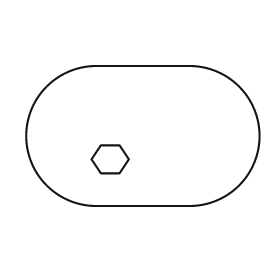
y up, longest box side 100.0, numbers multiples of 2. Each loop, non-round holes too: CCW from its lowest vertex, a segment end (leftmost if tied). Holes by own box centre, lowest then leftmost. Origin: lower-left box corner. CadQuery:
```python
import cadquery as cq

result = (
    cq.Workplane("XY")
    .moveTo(30.0, 0.0)
    .lineTo(70.0, 0.0)
    .threePointArc((100.0, 30.0), (70.0, 60.0))
    .lineTo(30.0, 60.0)
    .threePointArc((0.0, 30.0), (30.0, 0.0))
    .close()
    .moveTo(32.0, 14.0)
    .lineTo(40.0, 14.0)
    .lineTo(44.0, 20.0)
    .lineTo(40.0, 26.0)
    .lineTo(32.0, 26.0)
    .lineTo(28.0, 20.0)
    .close()
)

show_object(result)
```